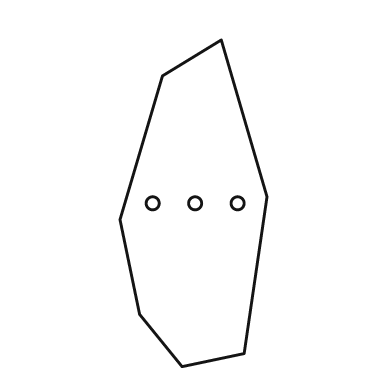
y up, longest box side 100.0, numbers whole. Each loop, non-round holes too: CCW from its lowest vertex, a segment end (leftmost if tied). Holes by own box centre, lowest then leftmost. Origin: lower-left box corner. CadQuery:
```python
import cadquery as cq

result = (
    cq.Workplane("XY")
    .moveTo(19.0, 0.0)
    .lineTo(38.0, 4.0)
    .lineTo(45.0, 52.0)
    .lineTo(31.0, 100.0)
    .lineTo(13.0, 89.0)
    .lineTo(0.0, 45.0)
    .lineTo(6.0, 16.0)
    .close()
    .moveTo(10.0, 50.0)
    .circle(2.0)
    .moveTo(23.0, 50.0)
    .circle(2.0)
    .moveTo(36.0, 50.0)
    .circle(2.0)
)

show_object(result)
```